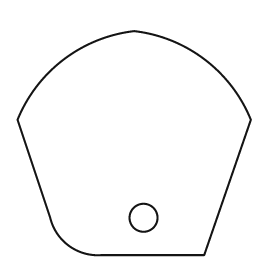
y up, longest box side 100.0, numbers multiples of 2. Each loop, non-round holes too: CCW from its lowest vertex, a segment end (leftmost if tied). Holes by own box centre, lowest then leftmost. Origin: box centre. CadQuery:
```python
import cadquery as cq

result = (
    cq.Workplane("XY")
    .moveTo(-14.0, -48.0)
    .lineTo(30.0, -48.0)
    .lineTo(50.0, 10.0)
    .threePointArc((30.0, 36.0), (0.0, 48.0))
    .threePointArc((-30.0, 36.0), (-50.0, 10.0))
    .lineTo(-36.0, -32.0)
    .threePointArc((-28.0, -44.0), (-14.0, -48.0))
    .close()
    .moveTo(4.0, -32.0)
    .circle(6.0)
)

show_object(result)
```